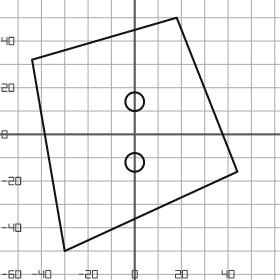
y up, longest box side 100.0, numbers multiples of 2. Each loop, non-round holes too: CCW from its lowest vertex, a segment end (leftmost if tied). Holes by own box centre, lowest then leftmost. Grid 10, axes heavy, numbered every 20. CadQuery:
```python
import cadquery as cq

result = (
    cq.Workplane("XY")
    .moveTo(-30.0, -50.0)
    .lineTo(44.0, -16.0)
    .lineTo(18.0, 50.0)
    .lineTo(-44.0, 32.0)
    .close()
    .moveTo(0.0, -12.0)
    .circle(4.0)
    .moveTo(0.0, 14.0)
    .circle(4.0)
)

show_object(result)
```